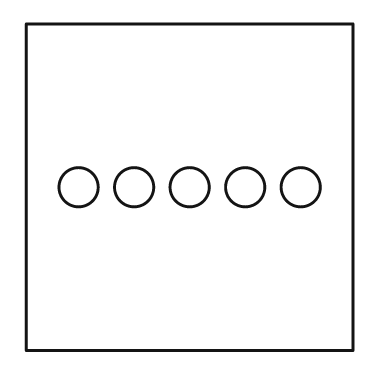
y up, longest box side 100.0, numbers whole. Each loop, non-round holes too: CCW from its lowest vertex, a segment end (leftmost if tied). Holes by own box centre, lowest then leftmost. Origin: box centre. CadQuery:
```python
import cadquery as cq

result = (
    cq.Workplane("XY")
    .moveTo(-50.0, -50.0)
    .lineTo(50.0, -50.0)
    .lineTo(50.0, 50.0)
    .lineTo(-50.0, 50.0)
    .close()
    .moveTo(-34.0, 0.0)
    .circle(6.0)
    .moveTo(-17.0, 0.0)
    .circle(6.0)
    .moveTo(0.0, 0.0)
    .circle(6.0)
    .moveTo(17.0, 0.0)
    .circle(6.0)
    .moveTo(34.0, 0.0)
    .circle(6.0)
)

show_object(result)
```